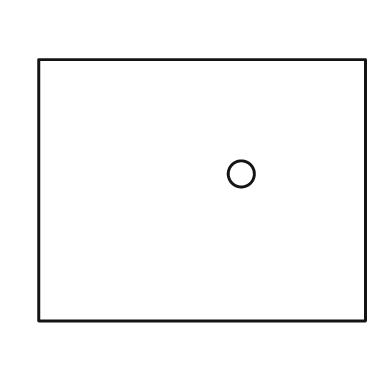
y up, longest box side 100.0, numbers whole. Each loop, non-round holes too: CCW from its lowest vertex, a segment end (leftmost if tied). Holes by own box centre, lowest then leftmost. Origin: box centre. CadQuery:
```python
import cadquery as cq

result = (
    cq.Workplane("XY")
    .moveTo(-50.0, -40.0)
    .lineTo(50.0, -40.0)
    .lineTo(50.0, 40.0)
    .lineTo(-50.0, 40.0)
    .close()
    .moveTo(12.0, 5.0)
    .circle(4.0)
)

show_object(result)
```